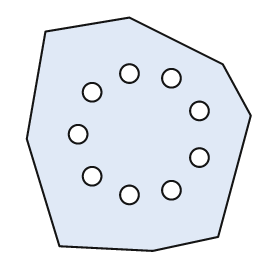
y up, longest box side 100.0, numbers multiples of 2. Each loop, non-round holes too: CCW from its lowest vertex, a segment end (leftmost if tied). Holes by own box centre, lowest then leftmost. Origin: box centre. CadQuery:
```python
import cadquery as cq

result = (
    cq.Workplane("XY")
    .moveTo(6.0, -50.0)
    .lineTo(34.0, -44.0)
    .lineTo(48.0, 8.0)
    .lineTo(36.0, 30.0)
    .lineTo(-4.0, 50.0)
    .lineTo(-40.0, 44.0)
    .lineTo(-48.0, -2.0)
    .lineTo(-34.0, -48.0)
    .close()
    .moveTo(-4.0, -26.0)
    .circle(4.0)
    .moveTo(14.0, -24.0)
    .circle(4.0)
    .moveTo(-20.0, -18.0)
    .circle(4.0)
    .moveTo(26.0, -10.0)
    .circle(4.0)
    .moveTo(-26.0, 0.0)
    .circle(4.0)
    .moveTo(26.0, 10.0)
    .circle(4.0)
    .moveTo(-20.0, 18.0)
    .circle(4.0)
    .moveTo(14.0, 24.0)
    .circle(4.0)
    .moveTo(-4.0, 26.0)
    .circle(4.0)
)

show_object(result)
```